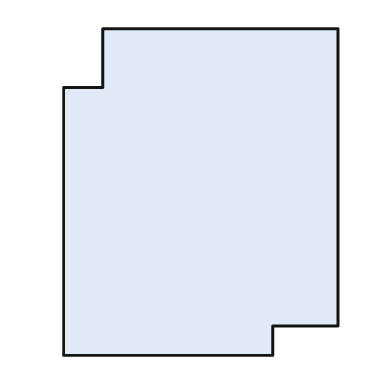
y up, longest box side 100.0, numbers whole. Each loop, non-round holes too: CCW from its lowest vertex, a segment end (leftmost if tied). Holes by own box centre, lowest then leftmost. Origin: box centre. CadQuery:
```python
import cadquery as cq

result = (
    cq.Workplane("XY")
    .moveTo(-42.0, -50.0)
    .lineTo(22.0, -50.0)
    .lineTo(22.0, -41.0)
    .lineTo(42.0, -41.0)
    .lineTo(42.0, 50.0)
    .lineTo(-30.0, 50.0)
    .lineTo(-30.0, 32.0)
    .lineTo(-42.0, 32.0)
    .close()
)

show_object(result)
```